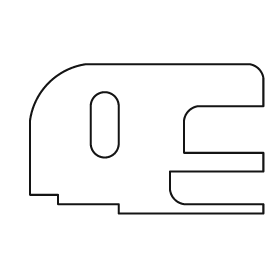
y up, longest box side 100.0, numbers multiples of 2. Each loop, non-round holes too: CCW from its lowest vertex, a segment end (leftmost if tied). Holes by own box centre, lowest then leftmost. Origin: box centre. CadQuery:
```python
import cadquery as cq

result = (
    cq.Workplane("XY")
    .moveTo(-12.0, -32.0)
    .lineTo(50.0, -32.0)
    .lineTo(50.0, -28.0)
    .lineTo(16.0, -28.0)
    .threePointArc((12.0, -26.0), (10.0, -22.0))
    .lineTo(10.0, -14.0)
    .lineTo(50.0, -14.0)
    .lineTo(50.0, -6.0)
    .lineTo(16.0, -6.0)
    .lineTo(16.0, 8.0)
    .threePointArc((18.0, 12.0), (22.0, 14.0))
    .lineTo(50.0, 14.0)
    .lineTo(50.0, 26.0)
    .threePointArc((48.0, 30.0), (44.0, 32.0))
    .lineTo(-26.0, 32.0)
    .threePointArc((-42.0, 24.0), (-50.0, 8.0))
    .lineTo(-50.0, -24.0)
    .lineTo(-38.0, -24.0)
    .lineTo(-38.0, -28.0)
    .lineTo(-12.0, -28.0)
    .close()
    .moveTo(-24.0, -2.0)
    .threePointArc((-18.0, -8.0), (-12.0, -2.0))
    .lineTo(-12.0, 14.0)
    .threePointArc((-18.0, 20.0), (-24.0, 14.0))
    .close()
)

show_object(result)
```